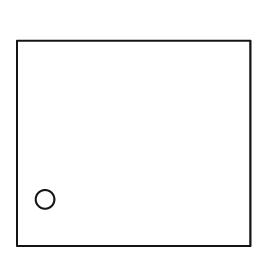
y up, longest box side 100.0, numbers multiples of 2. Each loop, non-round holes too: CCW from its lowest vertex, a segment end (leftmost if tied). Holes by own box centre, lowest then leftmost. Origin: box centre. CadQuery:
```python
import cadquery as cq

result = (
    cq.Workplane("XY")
    .moveTo(-50.0, -44.0)
    .lineTo(50.0, -44.0)
    .lineTo(50.0, 44.0)
    .lineTo(-50.0, 44.0)
    .close()
    .moveTo(-38.0, -24.0)
    .circle(4.0)
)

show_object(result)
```